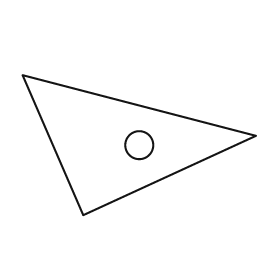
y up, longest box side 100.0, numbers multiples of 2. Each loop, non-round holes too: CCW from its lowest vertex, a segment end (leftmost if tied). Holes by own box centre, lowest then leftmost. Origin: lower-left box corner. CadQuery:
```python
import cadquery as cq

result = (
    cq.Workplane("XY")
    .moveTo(26.0, 0.0)
    .lineTo(100.0, 34.0)
    .lineTo(0.0, 60.0)
    .close()
    .moveTo(50.0, 30.0)
    .circle(6.0)
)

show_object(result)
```